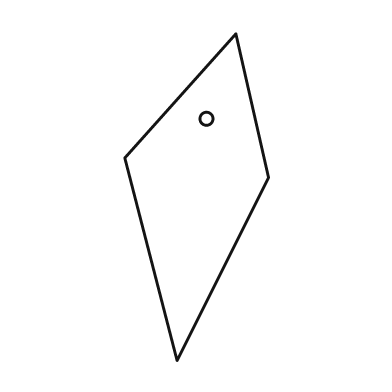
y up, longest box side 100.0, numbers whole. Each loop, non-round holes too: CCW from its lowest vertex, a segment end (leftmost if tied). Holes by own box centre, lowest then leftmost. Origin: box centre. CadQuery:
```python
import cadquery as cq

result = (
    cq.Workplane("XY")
    .moveTo(-6.0, -50.0)
    .lineTo(22.0, 6.0)
    .lineTo(12.0, 50.0)
    .lineTo(-22.0, 12.0)
    .close()
    .moveTo(3.0, 24.0)
    .circle(2.0)
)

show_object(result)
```